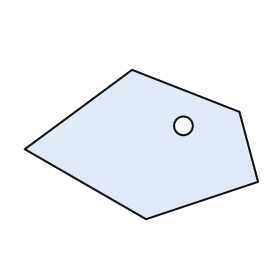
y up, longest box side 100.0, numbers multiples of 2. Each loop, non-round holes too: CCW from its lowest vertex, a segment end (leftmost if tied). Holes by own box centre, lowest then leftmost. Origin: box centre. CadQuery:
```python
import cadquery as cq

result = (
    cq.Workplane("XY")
    .moveTo(2.0, -32.0)
    .lineTo(50.0, -16.0)
    .lineTo(42.0, 14.0)
    .lineTo(-4.0, 32.0)
    .lineTo(-50.0, -2.0)
    .close()
    .moveTo(18.0, 8.0)
    .circle(4.0)
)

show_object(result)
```